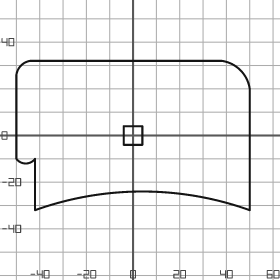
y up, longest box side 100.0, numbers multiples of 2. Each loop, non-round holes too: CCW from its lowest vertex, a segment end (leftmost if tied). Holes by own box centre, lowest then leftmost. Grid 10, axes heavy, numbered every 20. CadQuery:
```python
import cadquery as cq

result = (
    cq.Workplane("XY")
    .moveTo(-42.0, -32.0)
    .threePointArc((4.0, -24.0), (50.0, -32.0))
    .lineTo(50.0, 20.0)
    .threePointArc((46.0, 28.0), (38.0, 32.0))
    .lineTo(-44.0, 32.0)
    .threePointArc((-48.0, 30.0), (-50.0, 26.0))
    .lineTo(-50.0, -10.0)
    .threePointArc((-46.0, -12.0), (-42.0, -10.0))
    .close()
    .moveTo(-4.0, -4.0)
    .lineTo(4.0, -4.0)
    .lineTo(4.0, 4.0)
    .lineTo(-4.0, 4.0)
    .close()
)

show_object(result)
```